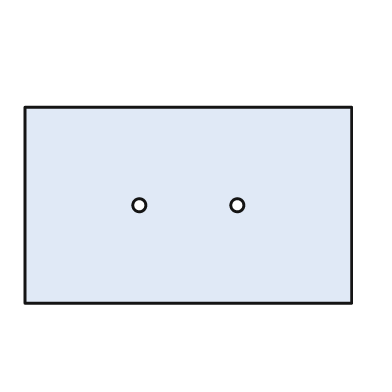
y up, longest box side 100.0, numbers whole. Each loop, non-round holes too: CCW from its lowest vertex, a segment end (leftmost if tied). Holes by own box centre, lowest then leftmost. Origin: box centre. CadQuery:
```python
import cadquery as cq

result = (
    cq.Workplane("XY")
    .moveTo(-50.0, -30.0)
    .lineTo(50.0, -30.0)
    .lineTo(50.0, 30.0)
    .lineTo(-50.0, 30.0)
    .close()
    .moveTo(-15.0, 0.0)
    .circle(2.0)
    .moveTo(15.0, 0.0)
    .circle(2.0)
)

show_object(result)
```